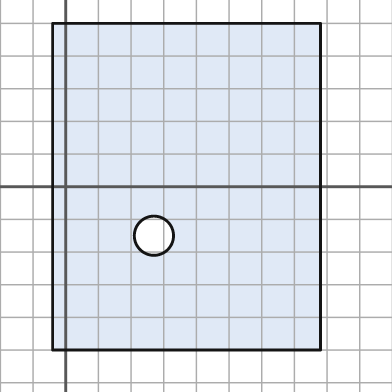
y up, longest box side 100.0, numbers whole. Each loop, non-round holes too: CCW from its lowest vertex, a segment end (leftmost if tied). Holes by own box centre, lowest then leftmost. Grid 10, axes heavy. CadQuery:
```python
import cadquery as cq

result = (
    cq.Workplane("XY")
    .moveTo(-4.0, -50.0)
    .lineTo(78.0, -50.0)
    .lineTo(78.0, 50.0)
    .lineTo(-4.0, 50.0)
    .close()
    .moveTo(27.0, -15.0)
    .circle(6.0)
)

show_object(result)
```